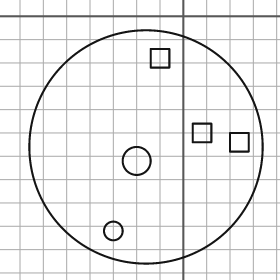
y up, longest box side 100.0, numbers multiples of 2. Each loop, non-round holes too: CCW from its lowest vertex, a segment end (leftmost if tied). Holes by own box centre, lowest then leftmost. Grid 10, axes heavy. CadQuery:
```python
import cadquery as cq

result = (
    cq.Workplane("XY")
    .moveTo(-16.0, -56.0)
    .circle(50.0)
    .moveTo(-30.0, -92.0)
    .circle(4.0)
    .moveTo(-20.0, -62.0)
    .circle(6.0)
    .moveTo(20.0, -58.0)
    .lineTo(28.0, -58.0)
    .lineTo(28.0, -50.0)
    .lineTo(20.0, -50.0)
    .close()
    .moveTo(4.0, -54.0)
    .lineTo(12.0, -54.0)
    .lineTo(12.0, -46.0)
    .lineTo(4.0, -46.0)
    .close()
    .moveTo(-14.0, -22.0)
    .lineTo(-6.0, -22.0)
    .lineTo(-6.0, -14.0)
    .lineTo(-14.0, -14.0)
    .close()
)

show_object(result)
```